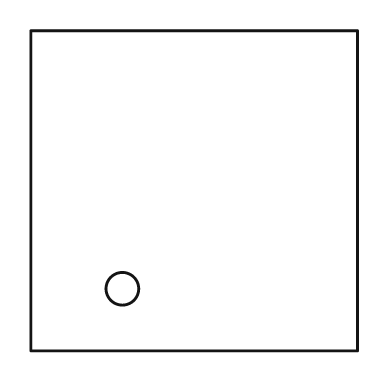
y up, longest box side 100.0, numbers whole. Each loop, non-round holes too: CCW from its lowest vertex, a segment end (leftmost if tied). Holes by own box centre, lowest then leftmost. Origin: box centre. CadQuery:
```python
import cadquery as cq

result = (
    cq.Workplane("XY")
    .moveTo(-50.0, -49.0)
    .lineTo(50.0, -49.0)
    .lineTo(50.0, 49.0)
    .lineTo(-50.0, 49.0)
    .close()
    .moveTo(-22.0, -30.0)
    .circle(5.0)
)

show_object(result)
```